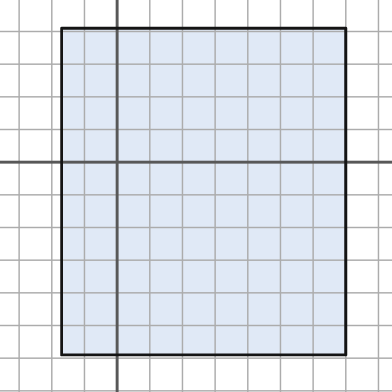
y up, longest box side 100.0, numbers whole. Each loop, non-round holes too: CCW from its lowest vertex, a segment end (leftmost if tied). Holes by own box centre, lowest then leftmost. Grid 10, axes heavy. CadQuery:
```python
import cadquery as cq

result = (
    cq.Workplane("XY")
    .moveTo(-17.0, -59.0)
    .lineTo(70.0, -59.0)
    .lineTo(70.0, 41.0)
    .lineTo(-17.0, 41.0)
    .close()
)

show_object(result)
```